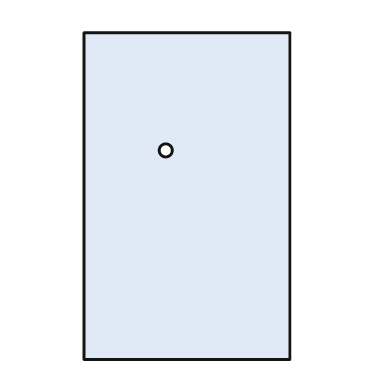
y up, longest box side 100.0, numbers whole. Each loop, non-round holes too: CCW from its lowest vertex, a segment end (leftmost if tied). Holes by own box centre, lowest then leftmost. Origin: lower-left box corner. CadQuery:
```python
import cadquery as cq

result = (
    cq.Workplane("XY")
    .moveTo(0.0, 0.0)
    .lineTo(63.0, 0.0)
    .lineTo(63.0, 100.0)
    .lineTo(0.0, 100.0)
    .close()
    .moveTo(25.0, 64.0)
    .circle(2.0)
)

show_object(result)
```